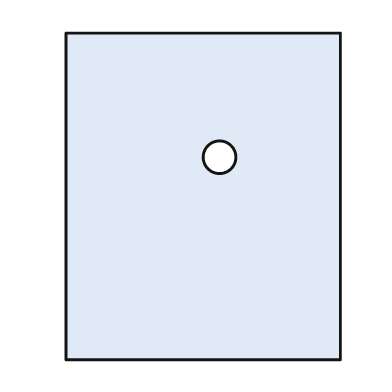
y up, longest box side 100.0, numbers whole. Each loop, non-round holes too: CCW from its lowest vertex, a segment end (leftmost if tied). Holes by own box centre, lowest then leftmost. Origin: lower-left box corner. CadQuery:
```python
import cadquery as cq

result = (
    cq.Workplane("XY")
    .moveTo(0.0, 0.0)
    .lineTo(84.0, 0.0)
    .lineTo(84.0, 100.0)
    .lineTo(0.0, 100.0)
    .close()
    .moveTo(47.0, 62.0)
    .circle(5.0)
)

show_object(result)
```